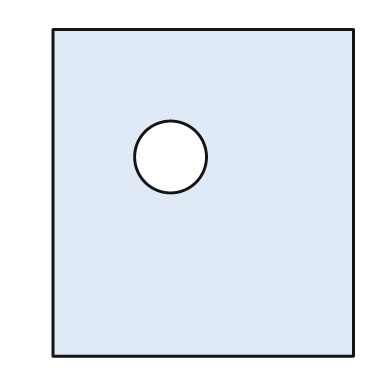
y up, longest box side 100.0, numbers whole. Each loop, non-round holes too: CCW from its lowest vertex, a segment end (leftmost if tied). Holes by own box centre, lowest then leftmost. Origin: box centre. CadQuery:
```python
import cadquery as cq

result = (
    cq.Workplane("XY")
    .moveTo(-46.0, -50.0)
    .lineTo(46.0, -50.0)
    .lineTo(46.0, 50.0)
    .lineTo(-46.0, 50.0)
    .close()
    .moveTo(-10.0, 11.0)
    .circle(11.0)
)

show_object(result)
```